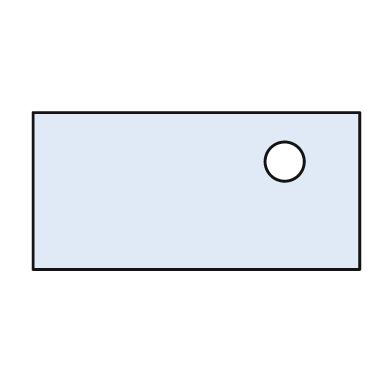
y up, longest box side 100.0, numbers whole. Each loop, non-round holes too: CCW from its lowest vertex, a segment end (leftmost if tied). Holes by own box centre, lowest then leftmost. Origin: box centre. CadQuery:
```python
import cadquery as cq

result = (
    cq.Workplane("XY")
    .moveTo(-50.0, -24.0)
    .lineTo(50.0, -24.0)
    .lineTo(50.0, 24.0)
    .lineTo(-50.0, 24.0)
    .close()
    .moveTo(27.0, 9.0)
    .circle(6.0)
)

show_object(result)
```